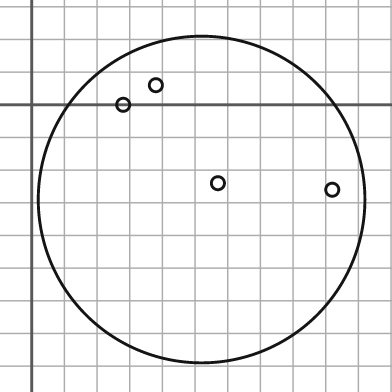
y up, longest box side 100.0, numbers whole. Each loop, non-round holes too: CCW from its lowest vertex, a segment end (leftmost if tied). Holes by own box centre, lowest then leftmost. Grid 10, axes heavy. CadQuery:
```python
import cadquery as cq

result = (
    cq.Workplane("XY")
    .moveTo(52.0, -29.0)
    .circle(50.0)
    .moveTo(92.0, -26.0)
    .circle(2.0)
    .moveTo(57.0, -24.0)
    .circle(2.0)
    .moveTo(28.0, 0.0)
    .circle(2.0)
    .moveTo(38.0, 6.0)
    .circle(2.0)
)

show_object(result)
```